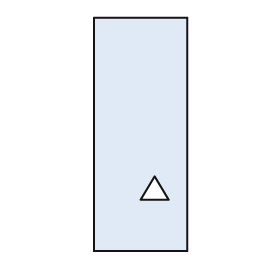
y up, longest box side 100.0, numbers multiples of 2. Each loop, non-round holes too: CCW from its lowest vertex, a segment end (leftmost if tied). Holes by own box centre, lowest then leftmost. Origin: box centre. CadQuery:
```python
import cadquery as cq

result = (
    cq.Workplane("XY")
    .moveTo(-20.0, -50.0)
    .lineTo(20.0, -50.0)
    .lineTo(20.0, 50.0)
    .lineTo(-20.0, 50.0)
    .close()
    .moveTo(0.0, -28.0)
    .lineTo(12.0, -28.0)
    .lineTo(6.0, -18.0)
    .close()
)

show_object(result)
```